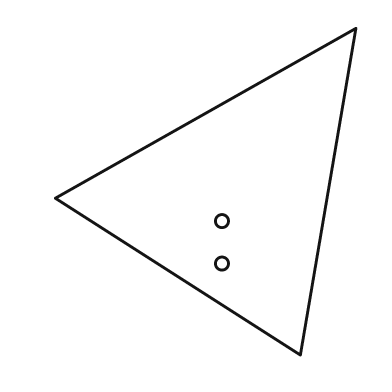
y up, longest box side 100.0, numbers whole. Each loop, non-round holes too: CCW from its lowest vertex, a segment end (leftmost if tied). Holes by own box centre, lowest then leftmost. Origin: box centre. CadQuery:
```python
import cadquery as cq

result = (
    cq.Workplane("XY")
    .moveTo(29.0, -50.0)
    .lineTo(46.0, 50.0)
    .lineTo(-46.0, -2.0)
    .close()
    .moveTo(5.0, -22.0)
    .circle(2.0)
    .moveTo(5.0, -9.0)
    .circle(2.0)
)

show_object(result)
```